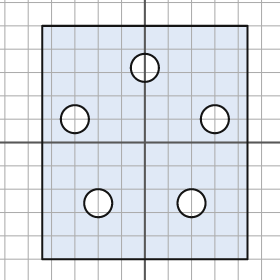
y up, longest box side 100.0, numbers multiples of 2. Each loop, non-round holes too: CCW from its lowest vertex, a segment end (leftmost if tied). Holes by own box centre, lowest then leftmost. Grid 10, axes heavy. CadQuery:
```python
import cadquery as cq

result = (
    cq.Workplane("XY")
    .moveTo(-44.0, -50.0)
    .lineTo(44.0, -50.0)
    .lineTo(44.0, 50.0)
    .lineTo(-44.0, 50.0)
    .close()
    .moveTo(-20.0, -26.0)
    .circle(6.0)
    .moveTo(20.0, -26.0)
    .circle(6.0)
    .moveTo(-30.0, 10.0)
    .circle(6.0)
    .moveTo(30.0, 10.0)
    .circle(6.0)
    .moveTo(0.0, 32.0)
    .circle(6.0)
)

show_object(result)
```